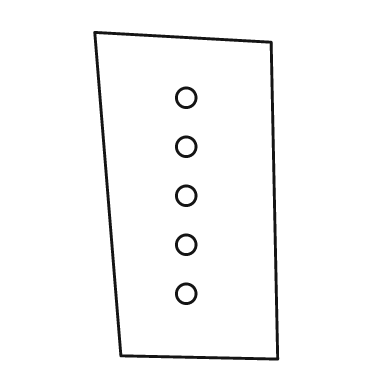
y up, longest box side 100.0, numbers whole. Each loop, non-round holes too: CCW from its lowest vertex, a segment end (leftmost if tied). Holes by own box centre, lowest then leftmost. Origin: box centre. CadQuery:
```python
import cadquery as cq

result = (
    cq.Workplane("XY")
    .moveTo(28.0, -50.0)
    .lineTo(26.0, 47.0)
    .lineTo(-28.0, 50.0)
    .lineTo(-20.0, -49.0)
    .close()
    .moveTo(0.0, -30.0)
    .circle(3.0)
    .moveTo(0.0, -15.0)
    .circle(3.0)
    .moveTo(0.0, 0.0)
    .circle(3.0)
    .moveTo(0.0, 15.0)
    .circle(3.0)
    .moveTo(0.0, 30.0)
    .circle(3.0)
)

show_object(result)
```